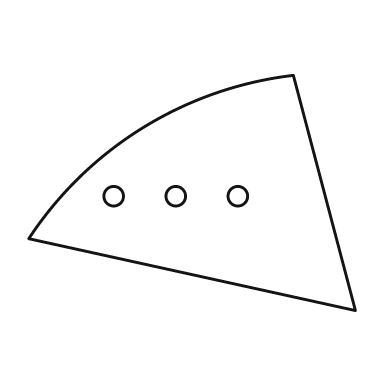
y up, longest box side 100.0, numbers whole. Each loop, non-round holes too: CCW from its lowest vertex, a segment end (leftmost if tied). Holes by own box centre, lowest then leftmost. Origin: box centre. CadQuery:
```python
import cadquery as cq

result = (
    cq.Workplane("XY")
    .moveTo(50.0, -36.0)
    .lineTo(31.0, 36.0)
    .threePointArc((-15.0, 20.0), (-50.0, -14.0))
    .close()
    .moveTo(-24.0, -1.0)
    .circle(3.0)
    .moveTo(-5.0, -1.0)
    .circle(3.0)
    .moveTo(14.0, -1.0)
    .circle(3.0)
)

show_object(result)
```